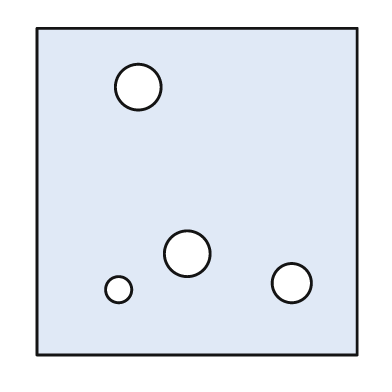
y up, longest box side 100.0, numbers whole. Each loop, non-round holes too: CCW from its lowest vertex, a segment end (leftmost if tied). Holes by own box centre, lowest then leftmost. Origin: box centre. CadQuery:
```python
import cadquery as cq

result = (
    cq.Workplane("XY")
    .moveTo(-49.0, -50.0)
    .lineTo(49.0, -50.0)
    .lineTo(49.0, 50.0)
    .lineTo(-49.0, 50.0)
    .close()
    .moveTo(-24.0, -30.0)
    .circle(4.0)
    .moveTo(29.0, -28.0)
    .circle(6.0)
    .moveTo(-3.0, -19.0)
    .circle(7.0)
    .moveTo(-18.0, 32.0)
    .circle(7.0)
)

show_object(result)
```